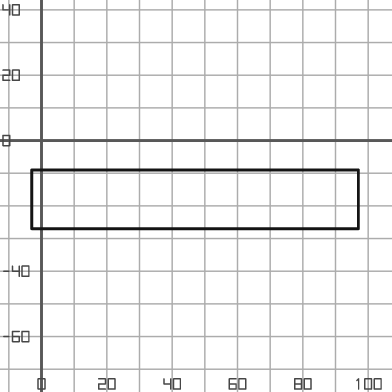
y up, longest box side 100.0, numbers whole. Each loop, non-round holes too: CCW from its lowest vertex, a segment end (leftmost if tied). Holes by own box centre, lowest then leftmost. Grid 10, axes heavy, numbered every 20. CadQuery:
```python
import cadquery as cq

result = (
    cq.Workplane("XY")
    .moveTo(-3.0, -27.0)
    .lineTo(97.0, -27.0)
    .lineTo(97.0, -9.0)
    .lineTo(-3.0, -9.0)
    .close()
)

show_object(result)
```